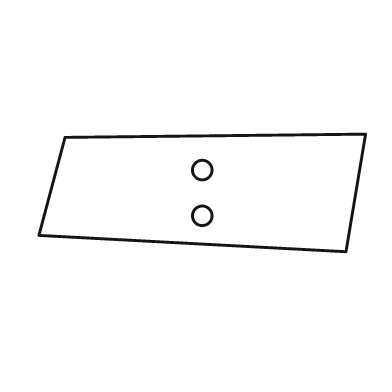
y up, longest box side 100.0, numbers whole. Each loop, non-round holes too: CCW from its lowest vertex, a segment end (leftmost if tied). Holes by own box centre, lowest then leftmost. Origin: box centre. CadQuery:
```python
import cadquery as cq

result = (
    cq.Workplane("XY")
    .moveTo(44.0, -18.0)
    .lineTo(50.0, 18.0)
    .lineTo(-42.0, 17.0)
    .lineTo(-50.0, -13.0)
    .close()
    .moveTo(0.0, -7.0)
    .circle(3.0)
    .moveTo(0.0, 7.0)
    .circle(3.0)
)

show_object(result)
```